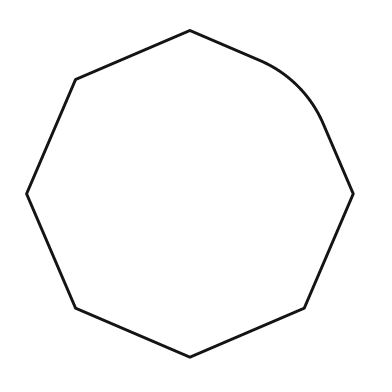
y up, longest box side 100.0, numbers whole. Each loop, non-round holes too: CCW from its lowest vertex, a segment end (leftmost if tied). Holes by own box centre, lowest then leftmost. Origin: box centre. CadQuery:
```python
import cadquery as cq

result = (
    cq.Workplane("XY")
    .moveTo(0.0, -50.0)
    .lineTo(35.0, -35.0)
    .lineTo(50.0, 0.0)
    .lineTo(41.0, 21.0)
    .threePointArc((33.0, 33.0), (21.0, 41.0))
    .lineTo(0.0, 50.0)
    .lineTo(-35.0, 35.0)
    .lineTo(-50.0, 0.0)
    .lineTo(-35.0, -35.0)
    .close()
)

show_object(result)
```